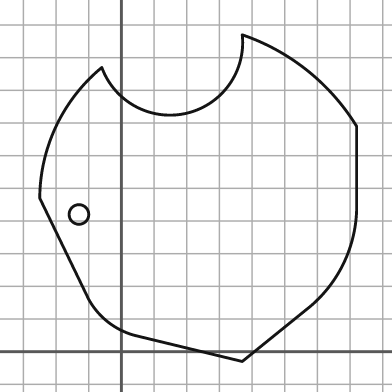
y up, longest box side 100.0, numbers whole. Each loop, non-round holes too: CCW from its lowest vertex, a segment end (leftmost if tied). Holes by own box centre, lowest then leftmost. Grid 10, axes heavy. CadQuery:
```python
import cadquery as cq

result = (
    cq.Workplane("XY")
    .moveTo(37.0, -3.0)
    .lineTo(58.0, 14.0)
    .threePointArc((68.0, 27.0), (72.0, 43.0))
    .lineTo(72.0, 69.0)
    .threePointArc((57.0, 86.0), (37.0, 97.0))
    .threePointArc((20.0, 73.0), (-6.0, 87.0))
    .threePointArc((-20.0, 69.0), (-25.0, 47.0))
    .lineTo(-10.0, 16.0)
    .threePointArc((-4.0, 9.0), (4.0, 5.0))
    .close()
    .moveTo(-13.0, 42.0)
    .circle(3.0)
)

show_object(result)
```